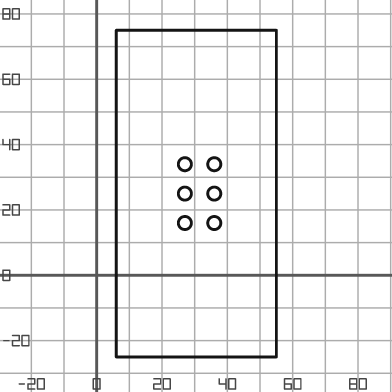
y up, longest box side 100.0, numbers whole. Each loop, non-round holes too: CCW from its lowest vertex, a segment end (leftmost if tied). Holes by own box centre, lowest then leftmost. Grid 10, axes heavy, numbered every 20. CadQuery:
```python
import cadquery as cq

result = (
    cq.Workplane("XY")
    .moveTo(6.0, -25.0)
    .lineTo(55.0, -25.0)
    .lineTo(55.0, 75.0)
    .lineTo(6.0, 75.0)
    .close()
    .moveTo(27.0, 16.0)
    .circle(2.0)
    .moveTo(36.0, 16.0)
    .circle(2.0)
    .moveTo(27.0, 25.0)
    .circle(2.0)
    .moveTo(36.0, 25.0)
    .circle(2.0)
    .moveTo(27.0, 34.0)
    .circle(2.0)
    .moveTo(36.0, 34.0)
    .circle(2.0)
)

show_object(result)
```